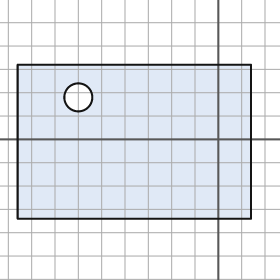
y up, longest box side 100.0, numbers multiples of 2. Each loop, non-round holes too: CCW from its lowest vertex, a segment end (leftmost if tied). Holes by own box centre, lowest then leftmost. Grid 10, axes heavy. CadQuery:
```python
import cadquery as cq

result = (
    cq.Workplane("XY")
    .moveTo(-86.0, -34.0)
    .lineTo(14.0, -34.0)
    .lineTo(14.0, 32.0)
    .lineTo(-86.0, 32.0)
    .close()
    .moveTo(-60.0, 18.0)
    .circle(6.0)
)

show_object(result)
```